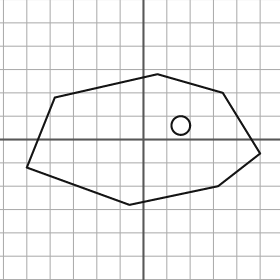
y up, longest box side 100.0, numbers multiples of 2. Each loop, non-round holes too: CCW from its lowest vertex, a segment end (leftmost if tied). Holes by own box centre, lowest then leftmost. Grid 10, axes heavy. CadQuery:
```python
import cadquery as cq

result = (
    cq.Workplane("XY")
    .moveTo(-6.0, -28.0)
    .lineTo(32.0, -20.0)
    .lineTo(50.0, -6.0)
    .lineTo(34.0, 20.0)
    .lineTo(6.0, 28.0)
    .lineTo(-38.0, 18.0)
    .lineTo(-50.0, -12.0)
    .close()
    .moveTo(16.0, 6.0)
    .circle(4.0)
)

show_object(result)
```